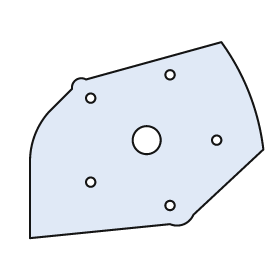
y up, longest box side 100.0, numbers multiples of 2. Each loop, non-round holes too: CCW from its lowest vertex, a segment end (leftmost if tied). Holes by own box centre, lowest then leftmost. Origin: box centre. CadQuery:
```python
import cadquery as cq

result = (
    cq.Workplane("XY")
    .moveTo(-50.0, -42.0)
    .lineTo(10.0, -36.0)
    .threePointArc((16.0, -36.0), (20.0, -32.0))
    .lineTo(50.0, -4.0)
    .threePointArc((44.0, 20.0), (32.0, 42.0))
    .lineTo(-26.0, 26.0)
    .threePointArc((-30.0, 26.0), (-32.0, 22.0))
    .lineTo(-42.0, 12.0)
    .threePointArc((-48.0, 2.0), (-50.0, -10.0))
    .close()
    .moveTo(10.0, -28.0)
    .circle(2.0)
    .moveTo(-24.0, -18.0)
    .circle(2.0)
    .moveTo(0.0, 0.0)
    .circle(6.0)
    .moveTo(30.0, 0.0)
    .circle(2.0)
    .moveTo(-24.0, 18.0)
    .circle(2.0)
    .moveTo(10.0, 28.0)
    .circle(2.0)
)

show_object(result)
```